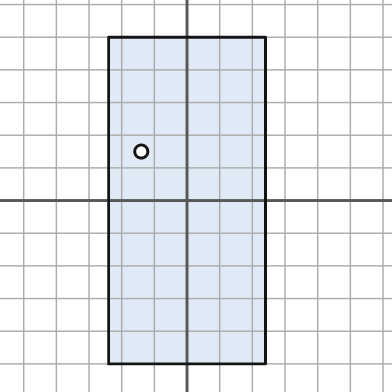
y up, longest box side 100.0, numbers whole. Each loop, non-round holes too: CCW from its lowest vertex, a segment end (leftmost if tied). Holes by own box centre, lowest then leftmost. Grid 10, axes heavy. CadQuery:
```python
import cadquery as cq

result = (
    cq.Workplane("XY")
    .moveTo(-24.0, -50.0)
    .lineTo(24.0, -50.0)
    .lineTo(24.0, 50.0)
    .lineTo(-24.0, 50.0)
    .close()
    .moveTo(-14.0, 15.0)
    .circle(2.0)
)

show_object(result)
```